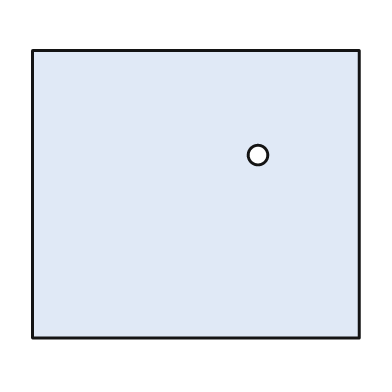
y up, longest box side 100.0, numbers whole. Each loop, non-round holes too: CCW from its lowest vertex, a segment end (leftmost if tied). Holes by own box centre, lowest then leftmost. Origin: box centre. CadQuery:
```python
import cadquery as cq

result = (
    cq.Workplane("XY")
    .moveTo(-50.0, -44.0)
    .lineTo(50.0, -44.0)
    .lineTo(50.0, 44.0)
    .lineTo(-50.0, 44.0)
    .close()
    .moveTo(19.0, 12.0)
    .circle(3.0)
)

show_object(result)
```